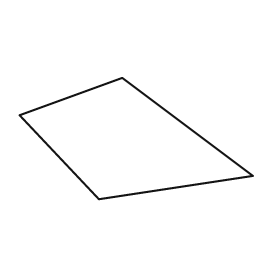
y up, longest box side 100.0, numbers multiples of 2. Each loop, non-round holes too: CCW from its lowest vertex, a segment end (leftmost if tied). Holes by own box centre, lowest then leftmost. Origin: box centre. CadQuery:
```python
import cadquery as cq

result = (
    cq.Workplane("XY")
    .moveTo(-16.0, -26.0)
    .lineTo(50.0, -16.0)
    .lineTo(-6.0, 26.0)
    .lineTo(-50.0, 10.0)
    .close()
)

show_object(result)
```